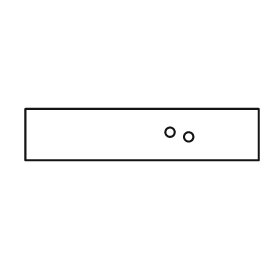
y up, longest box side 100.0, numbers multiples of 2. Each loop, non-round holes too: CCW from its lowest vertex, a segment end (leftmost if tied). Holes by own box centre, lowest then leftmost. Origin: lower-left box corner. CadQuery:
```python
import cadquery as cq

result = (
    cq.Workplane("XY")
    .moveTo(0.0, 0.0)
    .lineTo(100.0, 0.0)
    .lineTo(100.0, 22.0)
    .lineTo(0.0, 22.0)
    .close()
    .moveTo(70.0, 10.0)
    .circle(2.0)
    .moveTo(62.0, 12.0)
    .circle(2.0)
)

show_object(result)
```